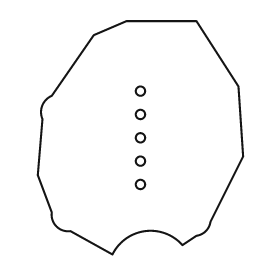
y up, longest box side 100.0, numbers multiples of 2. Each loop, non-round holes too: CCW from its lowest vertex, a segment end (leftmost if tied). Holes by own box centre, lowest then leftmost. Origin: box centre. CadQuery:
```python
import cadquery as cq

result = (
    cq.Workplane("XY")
    .moveTo(-12.0, -50.0)
    .threePointArc((2.0, -40.0), (18.0, -46.0))
    .lineTo(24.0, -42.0)
    .threePointArc((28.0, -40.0), (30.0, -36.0))
    .lineTo(44.0, -8.0)
    .lineTo(42.0, 22.0)
    .lineTo(24.0, 50.0)
    .lineTo(-6.0, 50.0)
    .lineTo(-20.0, 44.0)
    .lineTo(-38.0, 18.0)
    .threePointArc((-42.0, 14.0), (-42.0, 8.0))
    .lineTo(-44.0, -16.0)
    .lineTo(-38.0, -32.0)
    .threePointArc((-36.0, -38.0), (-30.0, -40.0))
    .close()
    .moveTo(0.0, -20.0)
    .circle(2.0)
    .moveTo(0.0, -10.0)
    .circle(2.0)
    .moveTo(0.0, 0.0)
    .circle(2.0)
    .moveTo(0.0, 10.0)
    .circle(2.0)
    .moveTo(0.0, 20.0)
    .circle(2.0)
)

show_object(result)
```